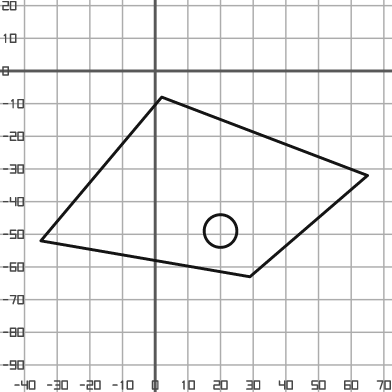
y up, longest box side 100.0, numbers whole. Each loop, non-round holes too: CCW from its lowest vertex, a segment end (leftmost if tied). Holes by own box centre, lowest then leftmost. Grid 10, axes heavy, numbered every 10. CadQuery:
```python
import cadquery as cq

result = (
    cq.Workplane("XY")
    .moveTo(29.0, -63.0)
    .lineTo(65.0, -32.0)
    .lineTo(2.0, -8.0)
    .lineTo(-35.0, -52.0)
    .close()
    .moveTo(20.0, -49.0)
    .circle(5.0)
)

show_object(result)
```